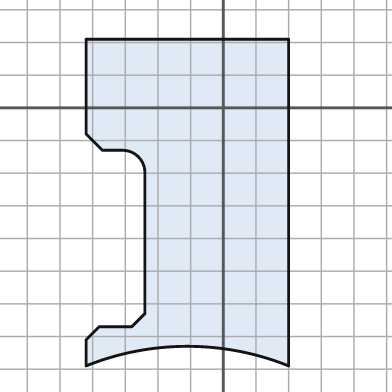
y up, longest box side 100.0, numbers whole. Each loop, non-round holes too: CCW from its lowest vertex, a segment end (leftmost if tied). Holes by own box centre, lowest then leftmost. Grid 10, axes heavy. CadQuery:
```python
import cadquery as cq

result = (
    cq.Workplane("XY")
    .moveTo(-42.0, -79.0)
    .threePointArc((-11.0, -73.0), (20.0, -79.0))
    .lineTo(20.0, 21.0)
    .lineTo(-42.0, 21.0)
    .lineTo(-42.0, -8.0)
    .lineTo(-37.0, -13.0)
    .lineTo(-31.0, -13.0)
    .threePointArc((-26.0, -15.0), (-24.0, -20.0))
    .lineTo(-24.0, -63.0)
    .lineTo(-28.0, -67.0)
    .lineTo(-38.0, -67.0)
    .lineTo(-42.0, -71.0)
    .close()
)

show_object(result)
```